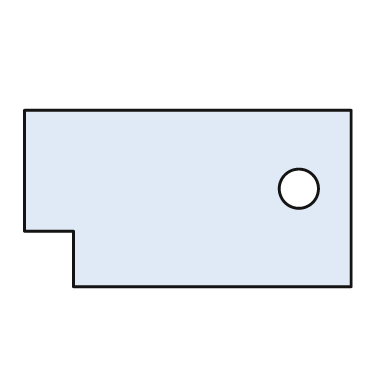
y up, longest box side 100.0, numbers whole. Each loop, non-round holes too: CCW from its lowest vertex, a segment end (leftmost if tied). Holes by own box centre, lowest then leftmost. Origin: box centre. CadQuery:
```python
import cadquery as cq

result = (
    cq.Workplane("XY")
    .moveTo(-35.0, -27.0)
    .lineTo(50.0, -27.0)
    .lineTo(50.0, 27.0)
    .lineTo(-50.0, 27.0)
    .lineTo(-50.0, -10.0)
    .lineTo(-35.0, -10.0)
    .close()
    .moveTo(34.0, 3.0)
    .circle(6.0)
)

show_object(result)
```